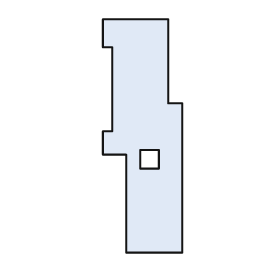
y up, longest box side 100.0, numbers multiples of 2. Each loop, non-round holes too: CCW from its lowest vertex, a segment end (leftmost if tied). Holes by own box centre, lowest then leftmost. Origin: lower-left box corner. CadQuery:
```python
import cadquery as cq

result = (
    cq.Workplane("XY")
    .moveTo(10.0, 0.0)
    .lineTo(34.0, 0.0)
    .lineTo(34.0, 64.0)
    .lineTo(28.0, 64.0)
    .lineTo(28.0, 100.0)
    .lineTo(0.0, 100.0)
    .lineTo(0.0, 88.0)
    .lineTo(4.0, 88.0)
    .lineTo(4.0, 52.0)
    .lineTo(0.0, 52.0)
    .lineTo(0.0, 42.0)
    .lineTo(10.0, 42.0)
    .close()
    .moveTo(16.0, 36.0)
    .lineTo(24.0, 36.0)
    .lineTo(24.0, 44.0)
    .lineTo(16.0, 44.0)
    .close()
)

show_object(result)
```